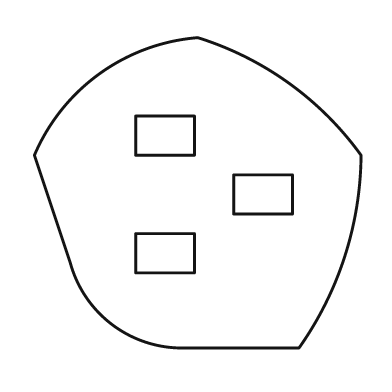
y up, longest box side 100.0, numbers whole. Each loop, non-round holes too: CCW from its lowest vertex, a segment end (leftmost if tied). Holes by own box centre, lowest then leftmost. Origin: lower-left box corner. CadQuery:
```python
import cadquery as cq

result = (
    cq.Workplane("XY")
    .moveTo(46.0, 0.0)
    .lineTo(81.0, 0.0)
    .threePointArc((95.0, 28.0), (100.0, 59.0))
    .threePointArc((78.0, 81.0), (50.0, 95.0))
    .threePointArc((20.0, 84.0), (0.0, 59.0))
    .lineTo(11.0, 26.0)
    .threePointArc((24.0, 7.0), (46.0, 0.0))
    .close()
    .moveTo(31.0, 23.0)
    .lineTo(49.0, 23.0)
    .lineTo(49.0, 35.0)
    .lineTo(31.0, 35.0)
    .close()
    .moveTo(61.0, 41.0)
    .lineTo(79.0, 41.0)
    .lineTo(79.0, 53.0)
    .lineTo(61.0, 53.0)
    .close()
    .moveTo(31.0, 59.0)
    .lineTo(49.0, 59.0)
    .lineTo(49.0, 71.0)
    .lineTo(31.0, 71.0)
    .close()
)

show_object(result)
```